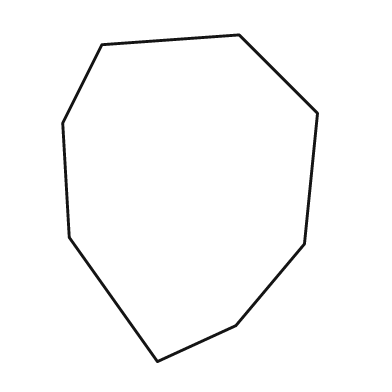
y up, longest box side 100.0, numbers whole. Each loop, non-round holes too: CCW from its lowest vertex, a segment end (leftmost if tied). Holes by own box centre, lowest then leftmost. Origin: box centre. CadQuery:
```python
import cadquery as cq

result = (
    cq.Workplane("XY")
    .moveTo(-10.0, -50.0)
    .lineTo(14.0, -39.0)
    .lineTo(35.0, -14.0)
    .lineTo(39.0, 26.0)
    .lineTo(15.0, 50.0)
    .lineTo(-27.0, 47.0)
    .lineTo(-39.0, 23.0)
    .lineTo(-37.0, -12.0)
    .close()
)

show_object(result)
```